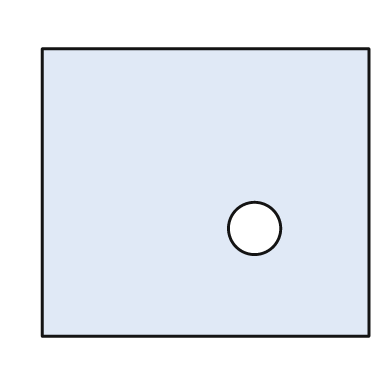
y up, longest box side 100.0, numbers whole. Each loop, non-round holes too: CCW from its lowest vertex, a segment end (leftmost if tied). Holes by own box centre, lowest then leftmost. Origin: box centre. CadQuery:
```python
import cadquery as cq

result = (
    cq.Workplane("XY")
    .moveTo(-50.0, -44.0)
    .lineTo(50.0, -44.0)
    .lineTo(50.0, 44.0)
    .lineTo(-50.0, 44.0)
    .close()
    .moveTo(15.0, -11.0)
    .circle(8.0)
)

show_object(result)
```